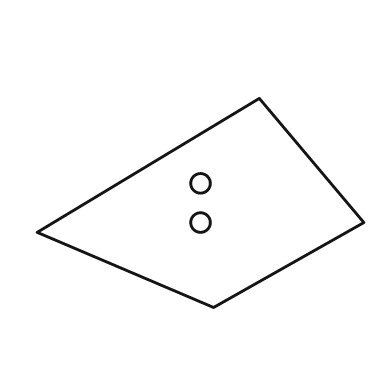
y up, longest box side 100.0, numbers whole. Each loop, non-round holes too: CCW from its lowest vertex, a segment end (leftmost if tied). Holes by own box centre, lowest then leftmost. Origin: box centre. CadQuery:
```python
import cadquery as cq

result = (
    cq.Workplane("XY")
    .moveTo(4.0, -32.0)
    .lineTo(50.0, -6.0)
    .lineTo(18.0, 32.0)
    .lineTo(-50.0, -9.0)
    .close()
    .moveTo(0.0, -6.0)
    .circle(3.0)
    .moveTo(0.0, 6.0)
    .circle(3.0)
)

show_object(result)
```